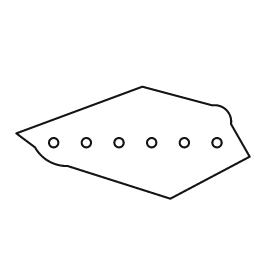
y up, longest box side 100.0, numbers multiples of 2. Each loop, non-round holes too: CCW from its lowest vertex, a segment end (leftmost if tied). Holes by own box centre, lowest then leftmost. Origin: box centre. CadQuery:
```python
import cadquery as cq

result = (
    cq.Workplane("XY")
    .moveTo(16.0, -24.0)
    .lineTo(50.0, -6.0)
    .lineTo(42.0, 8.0)
    .threePointArc((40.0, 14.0), (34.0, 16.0))
    .lineTo(4.0, 24.0)
    .lineTo(-50.0, 4.0)
    .lineTo(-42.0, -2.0)
    .threePointArc((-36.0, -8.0), (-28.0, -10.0))
    .close()
    .moveTo(-34.0, 0.0)
    .circle(2.0)
    .moveTo(-20.0, 0.0)
    .circle(2.0)
    .moveTo(-6.0, 0.0)
    .circle(2.0)
    .moveTo(8.0, 0.0)
    .circle(2.0)
    .moveTo(22.0, 0.0)
    .circle(2.0)
    .moveTo(36.0, 0.0)
    .circle(2.0)
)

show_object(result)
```